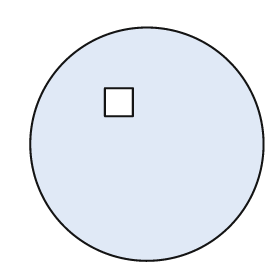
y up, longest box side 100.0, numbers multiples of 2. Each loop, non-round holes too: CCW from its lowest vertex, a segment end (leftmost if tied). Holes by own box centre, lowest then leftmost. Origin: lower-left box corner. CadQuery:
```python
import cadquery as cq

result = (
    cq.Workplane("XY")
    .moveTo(50.0, 50.0)
    .circle(50.0)
    .moveTo(32.0, 62.0)
    .lineTo(44.0, 62.0)
    .lineTo(44.0, 74.0)
    .lineTo(32.0, 74.0)
    .close()
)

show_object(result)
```